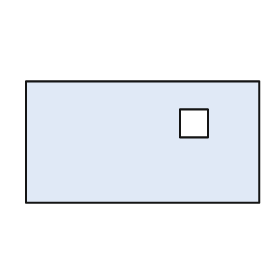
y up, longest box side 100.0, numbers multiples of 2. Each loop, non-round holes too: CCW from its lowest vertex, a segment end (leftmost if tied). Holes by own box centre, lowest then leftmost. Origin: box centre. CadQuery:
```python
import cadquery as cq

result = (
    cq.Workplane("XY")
    .moveTo(-50.0, -26.0)
    .lineTo(50.0, -26.0)
    .lineTo(50.0, 26.0)
    .lineTo(-50.0, 26.0)
    .close()
    .moveTo(16.0, 2.0)
    .lineTo(28.0, 2.0)
    .lineTo(28.0, 14.0)
    .lineTo(16.0, 14.0)
    .close()
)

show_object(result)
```